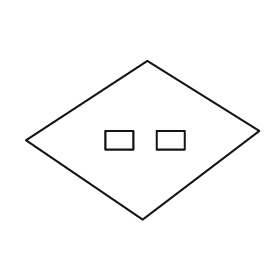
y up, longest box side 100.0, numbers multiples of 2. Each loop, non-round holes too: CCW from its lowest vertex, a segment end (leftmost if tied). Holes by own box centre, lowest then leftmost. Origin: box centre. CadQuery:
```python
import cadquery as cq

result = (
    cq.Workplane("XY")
    .moveTo(0.0, -34.0)
    .lineTo(50.0, 4.0)
    .lineTo(2.0, 34.0)
    .lineTo(-50.0, 0.0)
    .close()
    .moveTo(-16.0, -4.0)
    .lineTo(-4.0, -4.0)
    .lineTo(-4.0, 4.0)
    .lineTo(-16.0, 4.0)
    .close()
    .moveTo(6.0, -4.0)
    .lineTo(18.0, -4.0)
    .lineTo(18.0, 4.0)
    .lineTo(6.0, 4.0)
    .close()
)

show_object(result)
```